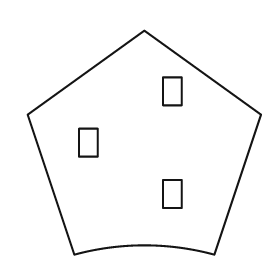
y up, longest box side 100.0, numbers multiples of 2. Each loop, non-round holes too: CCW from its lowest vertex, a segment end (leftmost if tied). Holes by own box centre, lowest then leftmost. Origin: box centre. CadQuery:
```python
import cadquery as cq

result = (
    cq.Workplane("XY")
    .moveTo(-30.0, -48.0)
    .threePointArc((0.0, -44.0), (30.0, -48.0))
    .lineTo(50.0, 12.0)
    .lineTo(0.0, 48.0)
    .lineTo(-50.0, 12.0)
    .close()
    .moveTo(8.0, -28.0)
    .lineTo(16.0, -28.0)
    .lineTo(16.0, -16.0)
    .lineTo(8.0, -16.0)
    .close()
    .moveTo(-28.0, -6.0)
    .lineTo(-20.0, -6.0)
    .lineTo(-20.0, 6.0)
    .lineTo(-28.0, 6.0)
    .close()
    .moveTo(8.0, 16.0)
    .lineTo(16.0, 16.0)
    .lineTo(16.0, 28.0)
    .lineTo(8.0, 28.0)
    .close()
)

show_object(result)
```